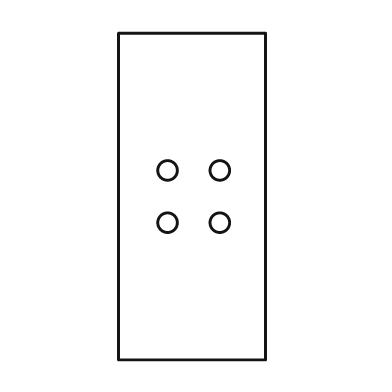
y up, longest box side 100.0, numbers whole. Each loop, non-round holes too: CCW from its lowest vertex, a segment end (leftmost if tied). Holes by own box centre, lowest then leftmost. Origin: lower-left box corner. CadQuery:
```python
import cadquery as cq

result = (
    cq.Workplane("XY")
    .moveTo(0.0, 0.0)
    .lineTo(45.0, 0.0)
    .lineTo(45.0, 100.0)
    .lineTo(0.0, 100.0)
    .close()
    .moveTo(15.0, 42.0)
    .circle(3.0)
    .moveTo(31.0, 42.0)
    .circle(3.0)
    .moveTo(15.0, 58.0)
    .circle(3.0)
    .moveTo(31.0, 58.0)
    .circle(3.0)
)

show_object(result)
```